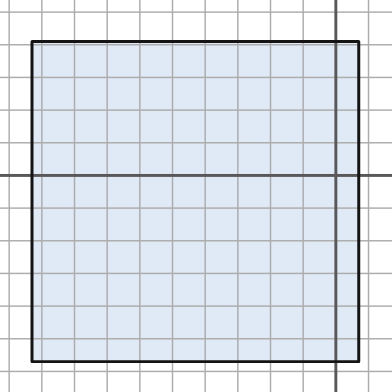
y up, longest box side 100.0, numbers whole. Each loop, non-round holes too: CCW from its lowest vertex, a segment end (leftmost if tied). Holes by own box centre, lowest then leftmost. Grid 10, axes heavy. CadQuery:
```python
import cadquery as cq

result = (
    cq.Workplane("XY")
    .moveTo(-93.0, -57.0)
    .lineTo(7.0, -57.0)
    .lineTo(7.0, 41.0)
    .lineTo(-93.0, 41.0)
    .close()
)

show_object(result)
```